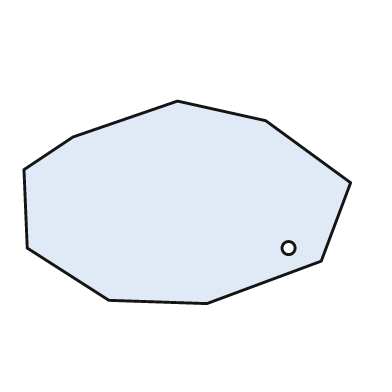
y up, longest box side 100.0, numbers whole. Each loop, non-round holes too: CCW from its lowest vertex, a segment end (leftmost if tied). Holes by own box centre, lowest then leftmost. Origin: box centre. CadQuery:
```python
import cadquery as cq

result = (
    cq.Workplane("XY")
    .moveTo(6.0, -31.0)
    .lineTo(41.0, -18.0)
    .lineTo(50.0, 6.0)
    .lineTo(24.0, 25.0)
    .lineTo(-3.0, 31.0)
    .lineTo(-35.0, 20.0)
    .lineTo(-50.0, 10.0)
    .lineTo(-49.0, -14.0)
    .lineTo(-24.0, -30.0)
    .close()
    .moveTo(31.0, -14.0)
    .circle(2.0)
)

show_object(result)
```